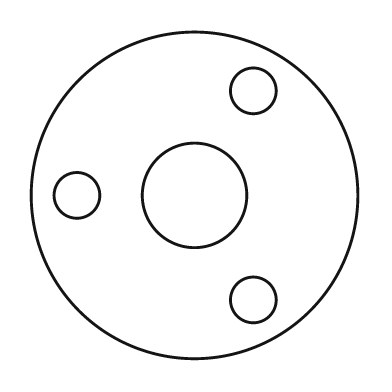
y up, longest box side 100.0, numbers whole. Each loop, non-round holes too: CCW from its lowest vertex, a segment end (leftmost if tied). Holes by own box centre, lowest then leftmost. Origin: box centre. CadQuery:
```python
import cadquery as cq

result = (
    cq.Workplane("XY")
    .moveTo(0.0, 0.0)
    .circle(50.0)
    .moveTo(18.0, -32.0)
    .circle(7.0)
    .moveTo(-36.0, 0.0)
    .circle(7.0)
    .moveTo(0.0, 0.0)
    .circle(16.0)
    .moveTo(18.0, 32.0)
    .circle(7.0)
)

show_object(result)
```